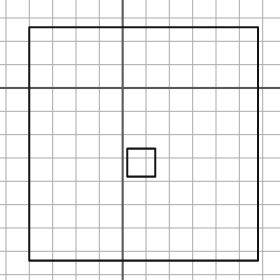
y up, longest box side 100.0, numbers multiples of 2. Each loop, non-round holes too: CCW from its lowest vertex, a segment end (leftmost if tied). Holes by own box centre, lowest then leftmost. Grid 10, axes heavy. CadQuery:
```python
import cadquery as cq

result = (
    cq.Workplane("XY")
    .moveTo(-40.0, -74.0)
    .lineTo(58.0, -74.0)
    .lineTo(58.0, 26.0)
    .lineTo(-40.0, 26.0)
    .close()
    .moveTo(2.0, -38.0)
    .lineTo(14.0, -38.0)
    .lineTo(14.0, -26.0)
    .lineTo(2.0, -26.0)
    .close()
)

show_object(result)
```